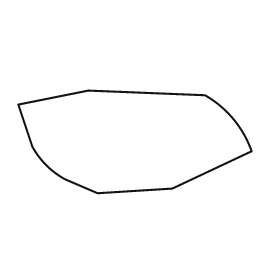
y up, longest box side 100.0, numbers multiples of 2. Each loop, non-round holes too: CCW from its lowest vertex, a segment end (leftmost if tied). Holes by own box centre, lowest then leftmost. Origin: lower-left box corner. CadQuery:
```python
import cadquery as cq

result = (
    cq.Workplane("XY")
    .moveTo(34.0, 0.0)
    .lineTo(66.0, 2.0)
    .lineTo(100.0, 18.0)
    .threePointArc((92.0, 32.0), (80.0, 42.0))
    .lineTo(30.0, 44.0)
    .lineTo(0.0, 38.0)
    .lineTo(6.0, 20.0)
    .threePointArc((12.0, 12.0), (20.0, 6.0))
    .close()
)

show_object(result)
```